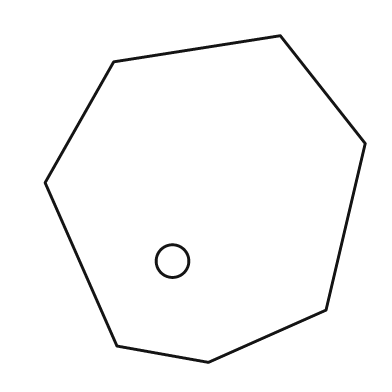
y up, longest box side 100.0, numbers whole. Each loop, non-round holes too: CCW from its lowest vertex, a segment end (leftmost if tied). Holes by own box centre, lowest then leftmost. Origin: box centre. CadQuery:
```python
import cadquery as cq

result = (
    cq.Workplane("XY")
    .moveTo(1.0, -50.0)
    .lineTo(37.0, -34.0)
    .lineTo(49.0, 17.0)
    .lineTo(23.0, 50.0)
    .lineTo(-28.0, 42.0)
    .lineTo(-49.0, 5.0)
    .lineTo(-27.0, -45.0)
    .close()
    .moveTo(-10.0, -19.0)
    .circle(5.0)
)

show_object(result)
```